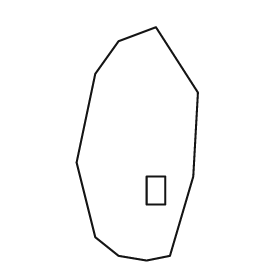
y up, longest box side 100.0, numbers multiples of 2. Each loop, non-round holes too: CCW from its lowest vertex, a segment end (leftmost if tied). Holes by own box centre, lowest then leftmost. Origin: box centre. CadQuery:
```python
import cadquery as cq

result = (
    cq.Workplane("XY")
    .moveTo(4.0, -50.0)
    .lineTo(14.0, -48.0)
    .lineTo(24.0, -14.0)
    .lineTo(26.0, 22.0)
    .lineTo(8.0, 50.0)
    .lineTo(-8.0, 44.0)
    .lineTo(-18.0, 30.0)
    .lineTo(-26.0, -8.0)
    .lineTo(-18.0, -40.0)
    .lineTo(-8.0, -48.0)
    .close()
    .moveTo(4.0, -26.0)
    .lineTo(12.0, -26.0)
    .lineTo(12.0, -14.0)
    .lineTo(4.0, -14.0)
    .close()
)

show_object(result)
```